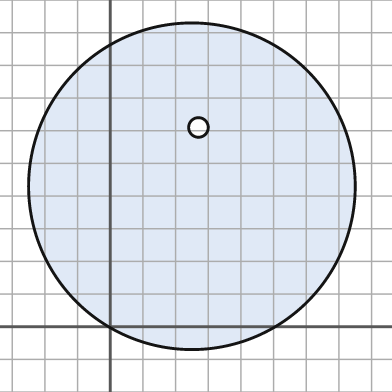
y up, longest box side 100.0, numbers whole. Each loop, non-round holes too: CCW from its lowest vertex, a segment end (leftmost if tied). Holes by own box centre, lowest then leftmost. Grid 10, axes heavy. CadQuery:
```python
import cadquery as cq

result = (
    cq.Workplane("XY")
    .moveTo(25.0, 43.0)
    .circle(50.0)
    .moveTo(27.0, 61.0)
    .circle(3.0)
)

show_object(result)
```